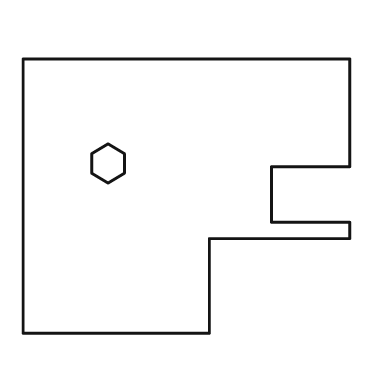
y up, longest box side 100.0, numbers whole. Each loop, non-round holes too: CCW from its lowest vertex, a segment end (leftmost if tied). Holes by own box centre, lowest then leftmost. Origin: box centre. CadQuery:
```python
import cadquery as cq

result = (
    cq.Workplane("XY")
    .moveTo(-50.0, -42.0)
    .lineTo(7.0, -42.0)
    .lineTo(7.0, -13.0)
    .lineTo(50.0, -13.0)
    .lineTo(50.0, -8.0)
    .lineTo(26.0, -8.0)
    .lineTo(26.0, 9.0)
    .lineTo(50.0, 9.0)
    .lineTo(50.0, 42.0)
    .lineTo(-50.0, 42.0)
    .close()
    .moveTo(-24.0, 4.0)
    .lineTo(-19.0, 7.0)
    .lineTo(-19.0, 13.0)
    .lineTo(-24.0, 16.0)
    .lineTo(-29.0, 13.0)
    .lineTo(-29.0, 7.0)
    .close()
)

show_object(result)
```